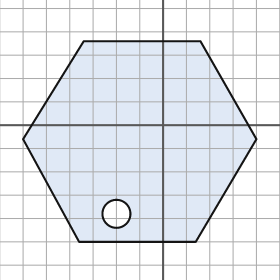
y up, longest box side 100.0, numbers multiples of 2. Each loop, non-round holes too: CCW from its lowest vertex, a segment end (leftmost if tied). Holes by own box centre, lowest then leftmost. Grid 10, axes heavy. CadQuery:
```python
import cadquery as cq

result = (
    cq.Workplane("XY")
    .moveTo(-36.0, -50.0)
    .lineTo(14.0, -50.0)
    .lineTo(40.0, -6.0)
    .lineTo(16.0, 36.0)
    .lineTo(-34.0, 36.0)
    .lineTo(-60.0, -6.0)
    .close()
    .moveTo(-20.0, -38.0)
    .circle(6.0)
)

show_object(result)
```